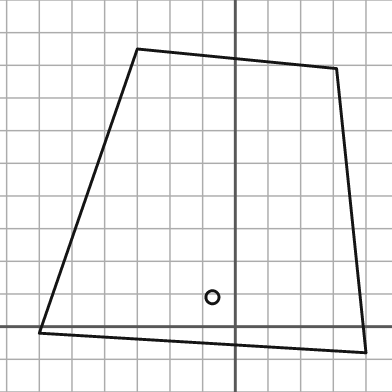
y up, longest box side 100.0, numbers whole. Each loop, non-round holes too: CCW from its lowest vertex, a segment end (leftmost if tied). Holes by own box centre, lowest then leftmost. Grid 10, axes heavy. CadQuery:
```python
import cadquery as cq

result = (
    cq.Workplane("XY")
    .moveTo(40.0, -8.0)
    .lineTo(31.0, 79.0)
    .lineTo(-30.0, 85.0)
    .lineTo(-60.0, -2.0)
    .close()
    .moveTo(-7.0, 9.0)
    .circle(2.0)
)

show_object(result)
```